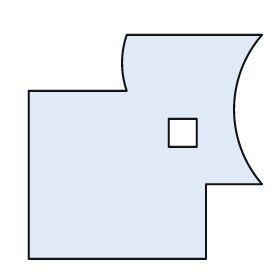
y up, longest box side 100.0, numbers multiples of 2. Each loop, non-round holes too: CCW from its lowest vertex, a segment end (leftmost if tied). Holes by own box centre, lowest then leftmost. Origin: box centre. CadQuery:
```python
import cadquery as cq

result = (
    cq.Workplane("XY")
    .moveTo(-50.0, -48.0)
    .lineTo(26.0, -48.0)
    .lineTo(26.0, -16.0)
    .lineTo(50.0, -16.0)
    .threePointArc((38.0, 16.0), (50.0, 48.0))
    .lineTo(-8.0, 48.0)
    .threePointArc((-10.0, 36.0), (-8.0, 24.0))
    .lineTo(-50.0, 24.0)
    .close()
    .moveTo(10.0, 0.0)
    .lineTo(22.0, 0.0)
    .lineTo(22.0, 12.0)
    .lineTo(10.0, 12.0)
    .close()
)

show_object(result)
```